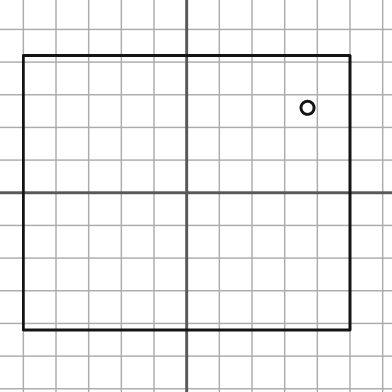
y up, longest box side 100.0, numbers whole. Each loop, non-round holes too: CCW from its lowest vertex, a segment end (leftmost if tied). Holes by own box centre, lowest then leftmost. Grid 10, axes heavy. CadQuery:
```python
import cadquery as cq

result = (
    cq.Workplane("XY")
    .moveTo(-50.0, -42.0)
    .lineTo(50.0, -42.0)
    .lineTo(50.0, 42.0)
    .lineTo(-50.0, 42.0)
    .close()
    .moveTo(37.0, 26.0)
    .circle(2.0)
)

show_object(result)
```